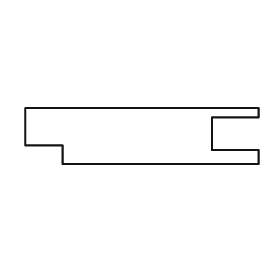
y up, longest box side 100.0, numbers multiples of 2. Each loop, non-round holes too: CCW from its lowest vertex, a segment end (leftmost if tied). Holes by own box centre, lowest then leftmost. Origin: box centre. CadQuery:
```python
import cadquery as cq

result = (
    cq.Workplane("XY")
    .moveTo(-34.0, -12.0)
    .lineTo(50.0, -12.0)
    .lineTo(50.0, -6.0)
    .lineTo(30.0, -6.0)
    .lineTo(30.0, 8.0)
    .lineTo(50.0, 8.0)
    .lineTo(50.0, 12.0)
    .lineTo(-50.0, 12.0)
    .lineTo(-50.0, -4.0)
    .lineTo(-34.0, -4.0)
    .close()
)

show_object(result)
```